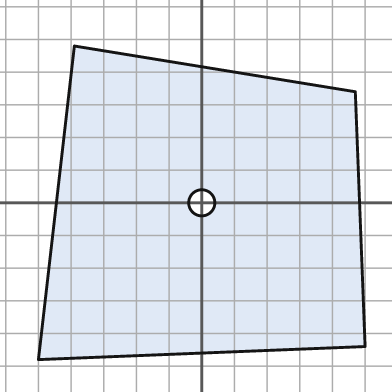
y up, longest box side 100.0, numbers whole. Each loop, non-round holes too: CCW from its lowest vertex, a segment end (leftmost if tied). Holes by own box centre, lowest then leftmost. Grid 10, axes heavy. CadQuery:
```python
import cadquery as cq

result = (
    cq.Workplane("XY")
    .moveTo(-50.0, -48.0)
    .lineTo(50.0, -44.0)
    .lineTo(47.0, 34.0)
    .lineTo(-39.0, 48.0)
    .close()
    .moveTo(0.0, 0.0)
    .circle(4.0)
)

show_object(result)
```